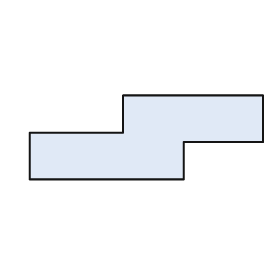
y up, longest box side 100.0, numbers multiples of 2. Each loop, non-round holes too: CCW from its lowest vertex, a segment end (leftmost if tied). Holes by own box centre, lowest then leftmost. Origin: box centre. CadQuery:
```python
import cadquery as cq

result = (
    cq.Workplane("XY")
    .moveTo(-50.0, -18.0)
    .lineTo(16.0, -18.0)
    .lineTo(16.0, -2.0)
    .lineTo(50.0, -2.0)
    .lineTo(50.0, 18.0)
    .lineTo(-10.0, 18.0)
    .lineTo(-10.0, 2.0)
    .lineTo(-50.0, 2.0)
    .close()
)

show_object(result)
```